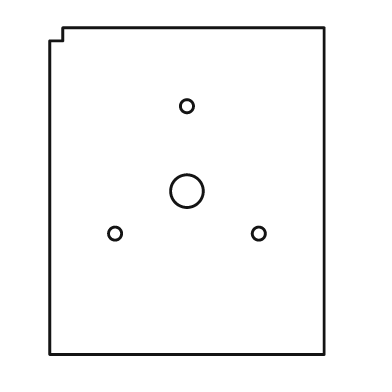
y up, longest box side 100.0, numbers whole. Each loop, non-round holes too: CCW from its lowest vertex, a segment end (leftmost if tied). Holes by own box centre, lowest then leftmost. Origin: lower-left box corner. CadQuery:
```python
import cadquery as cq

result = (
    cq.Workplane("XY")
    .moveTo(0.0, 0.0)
    .lineTo(84.0, 0.0)
    .lineTo(84.0, 100.0)
    .lineTo(4.0, 100.0)
    .lineTo(4.0, 96.0)
    .lineTo(0.0, 96.0)
    .close()
    .moveTo(20.0, 37.0)
    .circle(2.0)
    .moveTo(64.0, 37.0)
    .circle(2.0)
    .moveTo(42.0, 50.0)
    .circle(5.0)
    .moveTo(42.0, 76.0)
    .circle(2.0)
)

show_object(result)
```